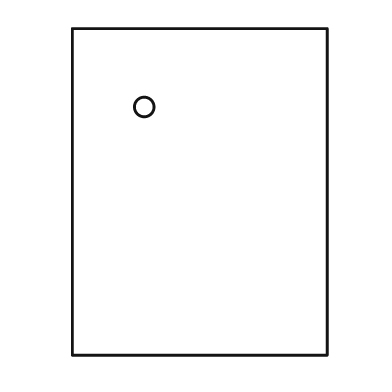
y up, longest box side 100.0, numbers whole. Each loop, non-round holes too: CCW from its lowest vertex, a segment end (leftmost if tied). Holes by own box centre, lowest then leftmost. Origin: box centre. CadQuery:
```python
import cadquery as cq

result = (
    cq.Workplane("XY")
    .moveTo(-39.0, -50.0)
    .lineTo(39.0, -50.0)
    .lineTo(39.0, 50.0)
    .lineTo(-39.0, 50.0)
    .close()
    .moveTo(-17.0, 26.0)
    .circle(3.0)
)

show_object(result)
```